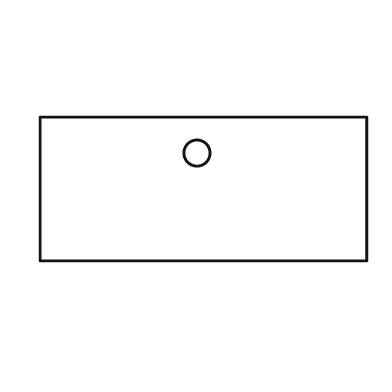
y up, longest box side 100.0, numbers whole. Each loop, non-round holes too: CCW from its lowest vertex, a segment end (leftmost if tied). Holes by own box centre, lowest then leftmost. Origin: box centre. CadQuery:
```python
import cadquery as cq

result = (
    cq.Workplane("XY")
    .moveTo(-50.0, -22.0)
    .lineTo(50.0, -22.0)
    .lineTo(50.0, 22.0)
    .lineTo(-50.0, 22.0)
    .close()
    .moveTo(-2.0, 11.0)
    .circle(4.0)
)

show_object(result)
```